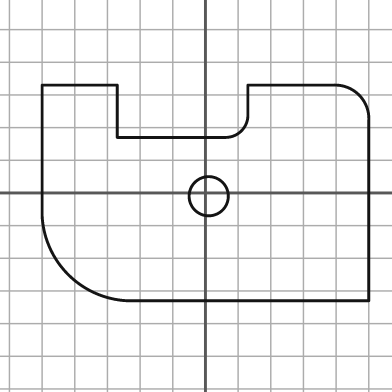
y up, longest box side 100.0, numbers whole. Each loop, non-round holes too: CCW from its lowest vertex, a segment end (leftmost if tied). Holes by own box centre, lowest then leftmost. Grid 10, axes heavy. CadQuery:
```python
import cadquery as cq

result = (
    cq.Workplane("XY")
    .moveTo(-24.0, -33.0)
    .lineTo(50.0, -33.0)
    .lineTo(50.0, 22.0)
    .threePointArc((47.0, 30.0), (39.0, 33.0))
    .lineTo(13.0, 33.0)
    .lineTo(13.0, 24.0)
    .threePointArc((11.0, 19.0), (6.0, 17.0))
    .lineTo(-27.0, 17.0)
    .lineTo(-27.0, 33.0)
    .lineTo(-50.0, 33.0)
    .lineTo(-50.0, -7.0)
    .threePointArc((-42.0, -25.0), (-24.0, -33.0))
    .close()
    .moveTo(1.0, -1.0)
    .circle(6.0)
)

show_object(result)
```